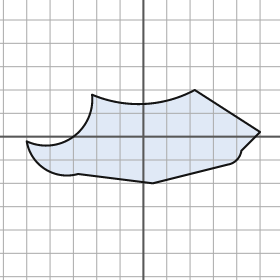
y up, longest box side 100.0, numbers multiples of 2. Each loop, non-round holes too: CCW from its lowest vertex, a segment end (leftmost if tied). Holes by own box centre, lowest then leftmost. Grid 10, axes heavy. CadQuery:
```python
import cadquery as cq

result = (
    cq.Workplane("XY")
    .moveTo(4.0, -20.0)
    .lineTo(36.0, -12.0)
    .threePointArc((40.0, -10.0), (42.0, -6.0))
    .lineTo(50.0, 2.0)
    .lineTo(22.0, 20.0)
    .threePointArc((0.0, 14.0), (-22.0, 18.0))
    .threePointArc((-30.0, 0.0), (-50.0, -2.0))
    .threePointArc((-42.0, -14.0), (-28.0, -16.0))
    .close()
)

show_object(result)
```